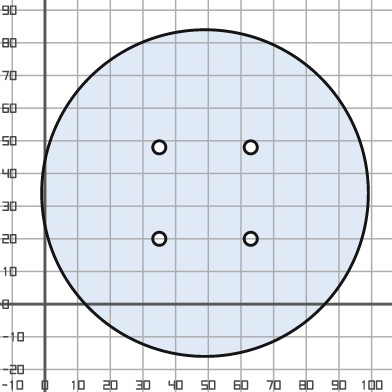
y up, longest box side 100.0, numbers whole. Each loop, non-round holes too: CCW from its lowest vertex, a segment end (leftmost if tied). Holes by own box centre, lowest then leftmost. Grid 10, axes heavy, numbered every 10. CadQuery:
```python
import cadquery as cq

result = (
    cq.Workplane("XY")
    .moveTo(49.0, 34.0)
    .circle(50.0)
    .moveTo(35.0, 20.0)
    .circle(2.0)
    .moveTo(63.0, 20.0)
    .circle(2.0)
    .moveTo(35.0, 48.0)
    .circle(2.0)
    .moveTo(63.0, 48.0)
    .circle(2.0)
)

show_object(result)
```